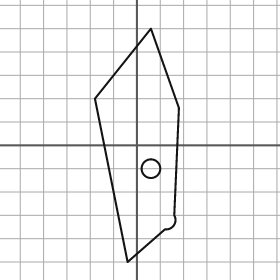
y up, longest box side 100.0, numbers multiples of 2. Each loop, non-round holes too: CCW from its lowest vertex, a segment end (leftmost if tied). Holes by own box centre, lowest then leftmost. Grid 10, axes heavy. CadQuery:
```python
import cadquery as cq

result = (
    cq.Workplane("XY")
    .moveTo(-4.0, -50.0)
    .lineTo(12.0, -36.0)
    .threePointArc((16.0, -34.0), (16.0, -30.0))
    .lineTo(18.0, 16.0)
    .lineTo(6.0, 50.0)
    .lineTo(-18.0, 20.0)
    .close()
    .moveTo(6.0, -10.0)
    .circle(4.0)
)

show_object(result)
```